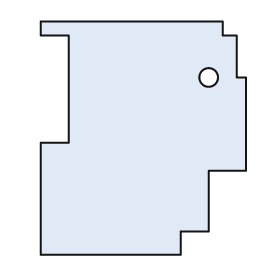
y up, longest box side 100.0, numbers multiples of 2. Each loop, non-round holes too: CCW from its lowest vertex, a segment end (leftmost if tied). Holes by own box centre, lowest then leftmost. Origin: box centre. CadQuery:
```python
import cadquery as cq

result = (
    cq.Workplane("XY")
    .moveTo(-44.0, -50.0)
    .lineTo(16.0, -50.0)
    .lineTo(16.0, -40.0)
    .lineTo(28.0, -40.0)
    .lineTo(28.0, -14.0)
    .lineTo(44.0, -14.0)
    .lineTo(44.0, 26.0)
    .lineTo(40.0, 26.0)
    .lineTo(40.0, 44.0)
    .lineTo(34.0, 44.0)
    .lineTo(34.0, 50.0)
    .lineTo(-44.0, 50.0)
    .lineTo(-44.0, 44.0)
    .lineTo(-32.0, 44.0)
    .lineTo(-32.0, -2.0)
    .lineTo(-44.0, -2.0)
    .close()
    .moveTo(28.0, 26.0)
    .circle(4.0)
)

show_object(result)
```